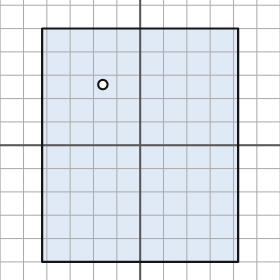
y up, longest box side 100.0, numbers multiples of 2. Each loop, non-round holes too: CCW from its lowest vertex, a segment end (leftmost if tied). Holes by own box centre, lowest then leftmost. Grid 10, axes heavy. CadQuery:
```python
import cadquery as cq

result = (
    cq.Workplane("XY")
    .moveTo(-42.0, -50.0)
    .lineTo(42.0, -50.0)
    .lineTo(42.0, 50.0)
    .lineTo(-42.0, 50.0)
    .close()
    .moveTo(-16.0, 26.0)
    .circle(2.0)
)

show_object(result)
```